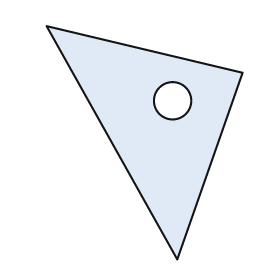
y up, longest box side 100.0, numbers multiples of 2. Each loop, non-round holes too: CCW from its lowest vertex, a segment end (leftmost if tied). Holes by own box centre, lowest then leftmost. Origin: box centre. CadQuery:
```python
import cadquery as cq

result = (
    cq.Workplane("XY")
    .moveTo(14.0, -50.0)
    .lineTo(42.0, 30.0)
    .lineTo(-42.0, 50.0)
    .close()
    .moveTo(12.0, 18.0)
    .circle(8.0)
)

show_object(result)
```